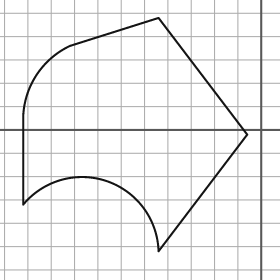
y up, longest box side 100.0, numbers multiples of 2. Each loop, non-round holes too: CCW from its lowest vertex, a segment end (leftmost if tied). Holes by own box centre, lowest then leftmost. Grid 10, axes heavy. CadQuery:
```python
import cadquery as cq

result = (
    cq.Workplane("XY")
    .moveTo(-44.0, -52.0)
    .lineTo(-6.0, -2.0)
    .lineTo(-44.0, 48.0)
    .lineTo(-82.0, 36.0)
    .threePointArc((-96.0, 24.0), (-102.0, 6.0))
    .lineTo(-102.0, -32.0)
    .threePointArc((-66.0, -22.0), (-44.0, -52.0))
    .close()
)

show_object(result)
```